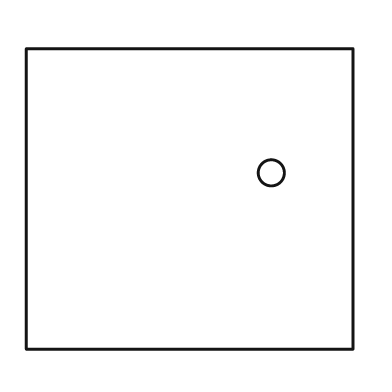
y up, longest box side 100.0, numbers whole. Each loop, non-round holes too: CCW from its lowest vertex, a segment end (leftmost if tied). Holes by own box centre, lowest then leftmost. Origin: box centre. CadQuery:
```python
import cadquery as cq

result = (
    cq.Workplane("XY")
    .moveTo(-50.0, -46.0)
    .lineTo(50.0, -46.0)
    .lineTo(50.0, 46.0)
    .lineTo(-50.0, 46.0)
    .close()
    .moveTo(25.0, 8.0)
    .circle(4.0)
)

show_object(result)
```